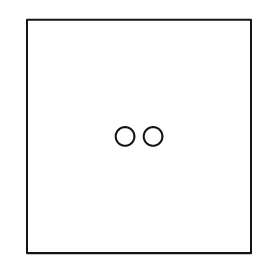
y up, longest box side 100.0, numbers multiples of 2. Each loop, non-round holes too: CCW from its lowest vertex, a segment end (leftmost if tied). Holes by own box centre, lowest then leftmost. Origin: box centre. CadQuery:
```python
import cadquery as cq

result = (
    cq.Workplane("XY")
    .moveTo(-48.0, -50.0)
    .lineTo(48.0, -50.0)
    .lineTo(48.0, 50.0)
    .lineTo(-48.0, 50.0)
    .close()
    .moveTo(-6.0, 0.0)
    .circle(4.0)
    .moveTo(6.0, 0.0)
    .circle(4.0)
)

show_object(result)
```